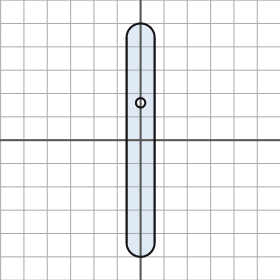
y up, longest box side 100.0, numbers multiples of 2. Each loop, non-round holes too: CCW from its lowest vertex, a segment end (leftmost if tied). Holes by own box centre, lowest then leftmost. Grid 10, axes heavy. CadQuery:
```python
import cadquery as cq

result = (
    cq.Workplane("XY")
    .moveTo(-6.0, -44.0)
    .threePointArc((0.0, -50.0), (6.0, -44.0))
    .lineTo(6.0, 44.0)
    .threePointArc((0.0, 50.0), (-6.0, 44.0))
    .close()
    .moveTo(0.0, 16.0)
    .circle(2.0)
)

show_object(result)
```